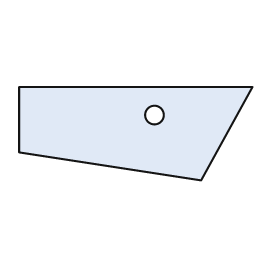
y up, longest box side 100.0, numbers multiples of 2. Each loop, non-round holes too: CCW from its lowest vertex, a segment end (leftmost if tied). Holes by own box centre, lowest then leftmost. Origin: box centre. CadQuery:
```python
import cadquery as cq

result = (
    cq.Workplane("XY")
    .moveTo(28.0, -20.0)
    .lineTo(50.0, 20.0)
    .lineTo(-50.0, 20.0)
    .lineTo(-50.0, -8.0)
    .close()
    .moveTo(8.0, 8.0)
    .circle(4.0)
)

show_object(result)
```